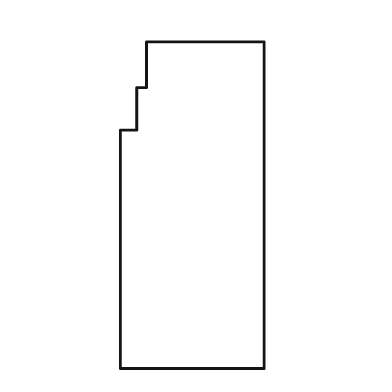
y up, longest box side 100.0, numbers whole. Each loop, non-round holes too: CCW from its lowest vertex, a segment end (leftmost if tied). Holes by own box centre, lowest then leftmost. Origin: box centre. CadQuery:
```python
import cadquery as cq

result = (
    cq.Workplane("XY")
    .moveTo(-22.0, -50.0)
    .lineTo(22.0, -50.0)
    .lineTo(22.0, 50.0)
    .lineTo(-14.0, 50.0)
    .lineTo(-14.0, 36.0)
    .lineTo(-17.0, 36.0)
    .lineTo(-17.0, 23.0)
    .lineTo(-22.0, 23.0)
    .close()
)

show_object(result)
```